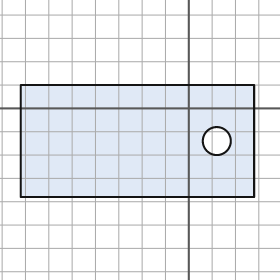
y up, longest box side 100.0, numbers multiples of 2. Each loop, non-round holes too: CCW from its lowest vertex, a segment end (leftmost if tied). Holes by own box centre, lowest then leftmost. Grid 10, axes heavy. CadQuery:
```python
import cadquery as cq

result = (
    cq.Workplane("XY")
    .moveTo(-72.0, -38.0)
    .lineTo(28.0, -38.0)
    .lineTo(28.0, 10.0)
    .lineTo(-72.0, 10.0)
    .close()
    .moveTo(12.0, -14.0)
    .circle(6.0)
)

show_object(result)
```